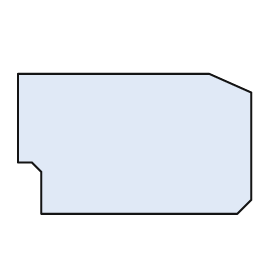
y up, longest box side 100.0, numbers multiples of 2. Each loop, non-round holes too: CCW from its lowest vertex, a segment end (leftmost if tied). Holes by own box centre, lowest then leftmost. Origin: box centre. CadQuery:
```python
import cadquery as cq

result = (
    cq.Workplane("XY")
    .moveTo(-40.0, -30.0)
    .lineTo(44.0, -30.0)
    .lineTo(50.0, -24.0)
    .lineTo(50.0, 22.0)
    .lineTo(32.0, 30.0)
    .lineTo(-50.0, 30.0)
    .lineTo(-50.0, -8.0)
    .lineTo(-44.0, -8.0)
    .lineTo(-40.0, -12.0)
    .close()
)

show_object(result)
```